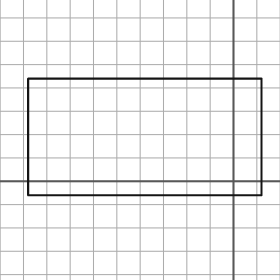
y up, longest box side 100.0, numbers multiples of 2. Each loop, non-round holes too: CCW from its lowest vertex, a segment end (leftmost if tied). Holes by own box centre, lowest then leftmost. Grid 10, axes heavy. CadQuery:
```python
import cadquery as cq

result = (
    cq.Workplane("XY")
    .moveTo(-88.0, -6.0)
    .lineTo(12.0, -6.0)
    .lineTo(12.0, 44.0)
    .lineTo(-88.0, 44.0)
    .close()
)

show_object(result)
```